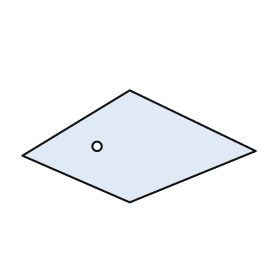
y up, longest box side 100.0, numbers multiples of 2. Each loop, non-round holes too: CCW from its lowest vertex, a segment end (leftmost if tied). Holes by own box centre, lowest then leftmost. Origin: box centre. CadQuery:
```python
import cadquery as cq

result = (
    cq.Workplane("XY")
    .moveTo(-4.0, -24.0)
    .lineTo(50.0, -2.0)
    .lineTo(-4.0, 24.0)
    .lineTo(-50.0, -4.0)
    .close()
    .moveTo(-18.0, 0.0)
    .circle(2.0)
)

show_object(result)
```